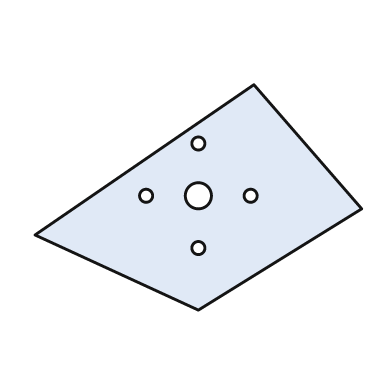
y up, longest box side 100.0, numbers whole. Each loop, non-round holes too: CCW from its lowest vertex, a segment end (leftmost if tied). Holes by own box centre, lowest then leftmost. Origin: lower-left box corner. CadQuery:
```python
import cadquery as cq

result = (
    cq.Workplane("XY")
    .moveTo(50.0, 0.0)
    .lineTo(100.0, 31.0)
    .lineTo(67.0, 69.0)
    .lineTo(0.0, 23.0)
    .close()
    .moveTo(50.0, 19.0)
    .circle(2.0)
    .moveTo(34.0, 35.0)
    .circle(2.0)
    .moveTo(50.0, 35.0)
    .circle(4.0)
    .moveTo(66.0, 35.0)
    .circle(2.0)
    .moveTo(50.0, 51.0)
    .circle(2.0)
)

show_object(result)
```